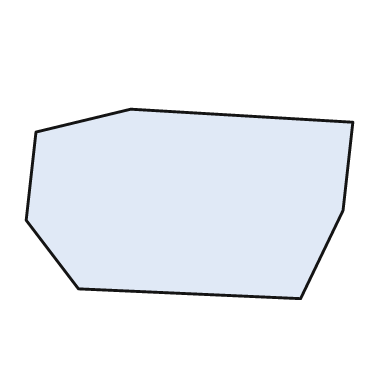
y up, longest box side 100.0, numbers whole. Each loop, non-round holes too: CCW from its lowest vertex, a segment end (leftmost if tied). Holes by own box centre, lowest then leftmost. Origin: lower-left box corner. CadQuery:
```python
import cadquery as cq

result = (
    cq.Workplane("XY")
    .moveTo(84.0, 0.0)
    .lineTo(97.0, 27.0)
    .lineTo(100.0, 54.0)
    .lineTo(32.0, 58.0)
    .lineTo(3.0, 51.0)
    .lineTo(0.0, 24.0)
    .lineTo(16.0, 3.0)
    .close()
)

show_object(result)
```